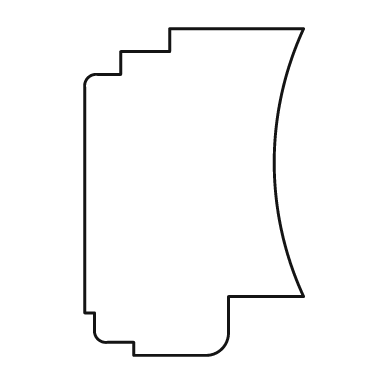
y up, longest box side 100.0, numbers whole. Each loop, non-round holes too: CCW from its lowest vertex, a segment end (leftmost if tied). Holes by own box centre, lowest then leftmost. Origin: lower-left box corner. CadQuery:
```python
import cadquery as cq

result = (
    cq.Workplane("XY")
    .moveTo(15.0, 0.0)
    .lineTo(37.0, 0.0)
    .threePointArc((42.0, 2.0), (44.0, 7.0))
    .lineTo(44.0, 18.0)
    .lineTo(67.0, 18.0)
    .threePointArc((58.0, 59.0), (67.0, 100.0))
    .lineTo(26.0, 100.0)
    .lineTo(26.0, 93.0)
    .lineTo(11.0, 93.0)
    .lineTo(11.0, 86.0)
    .lineTo(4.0, 86.0)
    .threePointArc((1.0, 85.0), (0.0, 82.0))
    .lineTo(0.0, 13.0)
    .lineTo(3.0, 13.0)
    .lineTo(3.0, 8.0)
    .threePointArc((4.0, 5.0), (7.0, 4.0))
    .lineTo(15.0, 4.0)
    .close()
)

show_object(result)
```